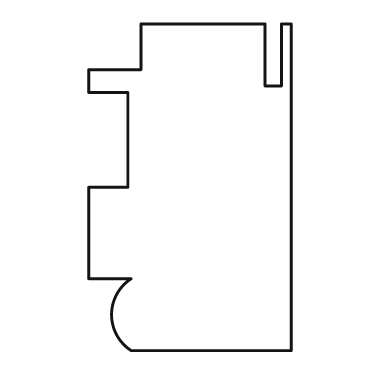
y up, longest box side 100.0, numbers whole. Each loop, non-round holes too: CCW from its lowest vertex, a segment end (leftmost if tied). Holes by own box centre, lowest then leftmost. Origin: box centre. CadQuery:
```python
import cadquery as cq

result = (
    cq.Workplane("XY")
    .moveTo(-18.0, -50.0)
    .lineTo(31.0, -50.0)
    .lineTo(31.0, 50.0)
    .lineTo(28.0, 50.0)
    .lineTo(28.0, 31.0)
    .lineTo(23.0, 31.0)
    .lineTo(23.0, 50.0)
    .lineTo(-15.0, 50.0)
    .lineTo(-15.0, 36.0)
    .lineTo(-31.0, 36.0)
    .lineTo(-31.0, 29.0)
    .lineTo(-19.0, 29.0)
    .lineTo(-19.0, 0.0)
    .lineTo(-31.0, 0.0)
    .lineTo(-31.0, -28.0)
    .lineTo(-18.0, -28.0)
    .threePointArc((-24.0, -39.0), (-18.0, -50.0))
    .close()
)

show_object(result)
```